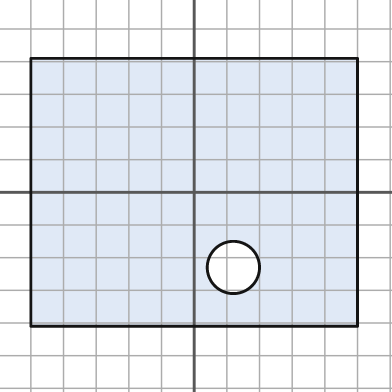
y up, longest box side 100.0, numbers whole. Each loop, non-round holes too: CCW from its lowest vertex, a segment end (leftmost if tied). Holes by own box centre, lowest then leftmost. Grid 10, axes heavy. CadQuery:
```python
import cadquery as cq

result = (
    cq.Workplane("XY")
    .moveTo(-50.0, -41.0)
    .lineTo(50.0, -41.0)
    .lineTo(50.0, 41.0)
    .lineTo(-50.0, 41.0)
    .close()
    .moveTo(12.0, -23.0)
    .circle(8.0)
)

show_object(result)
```